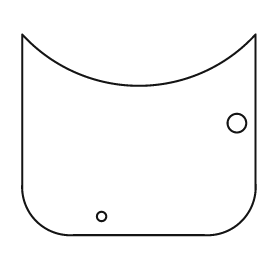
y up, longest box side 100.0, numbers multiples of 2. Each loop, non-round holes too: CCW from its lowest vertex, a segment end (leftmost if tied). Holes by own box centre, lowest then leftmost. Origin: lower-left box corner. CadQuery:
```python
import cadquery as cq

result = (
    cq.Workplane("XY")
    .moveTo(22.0, 0.0)
    .lineTo(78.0, 0.0)
    .threePointArc((94.0, 6.0), (100.0, 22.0))
    .lineTo(100.0, 86.0)
    .threePointArc((50.0, 64.0), (0.0, 86.0))
    .lineTo(0.0, 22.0)
    .threePointArc((6.0, 6.0), (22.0, 0.0))
    .close()
    .moveTo(34.0, 8.0)
    .circle(2.0)
    .moveTo(92.0, 48.0)
    .circle(4.0)
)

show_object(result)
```